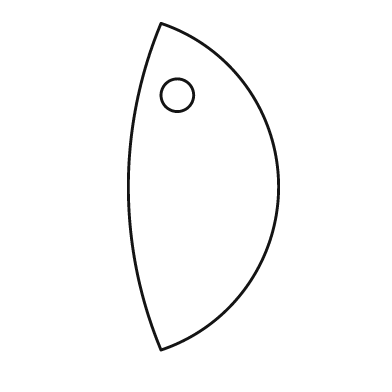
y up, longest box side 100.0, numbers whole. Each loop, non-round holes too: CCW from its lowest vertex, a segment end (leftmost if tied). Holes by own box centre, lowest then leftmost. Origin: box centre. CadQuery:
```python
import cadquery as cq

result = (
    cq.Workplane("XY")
    .moveTo(-13.0, -50.0)
    .threePointArc((23.0, 0.0), (-13.0, 50.0))
    .threePointArc((-23.0, 0.0), (-13.0, -50.0))
    .close()
    .moveTo(-8.0, 28.0)
    .circle(5.0)
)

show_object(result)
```